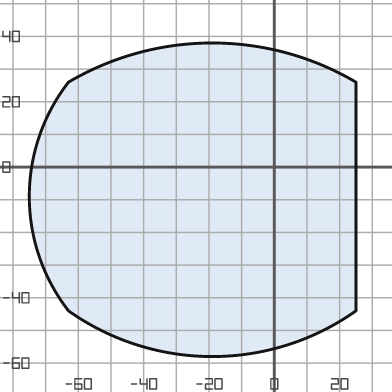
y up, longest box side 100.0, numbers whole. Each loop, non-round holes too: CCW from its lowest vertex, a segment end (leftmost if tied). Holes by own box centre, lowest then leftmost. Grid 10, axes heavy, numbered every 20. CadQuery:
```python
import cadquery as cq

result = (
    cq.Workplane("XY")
    .moveTo(-63.0, -44.0)
    .threePointArc((-19.0, -58.0), (25.0, -44.0))
    .lineTo(25.0, 26.0)
    .threePointArc((-19.0, 38.0), (-63.0, 26.0))
    .threePointArc((-75.0, -9.0), (-63.0, -44.0))
    .close()
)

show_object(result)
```